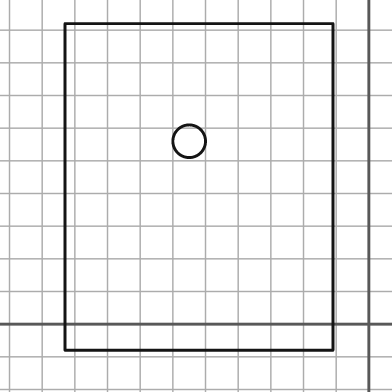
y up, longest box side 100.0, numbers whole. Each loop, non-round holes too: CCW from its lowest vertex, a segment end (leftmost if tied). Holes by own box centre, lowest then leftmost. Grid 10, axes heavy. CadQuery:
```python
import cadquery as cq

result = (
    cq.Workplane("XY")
    .moveTo(-93.0, -8.0)
    .lineTo(-11.0, -8.0)
    .lineTo(-11.0, 92.0)
    .lineTo(-93.0, 92.0)
    .close()
    .moveTo(-55.0, 56.0)
    .circle(5.0)
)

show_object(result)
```